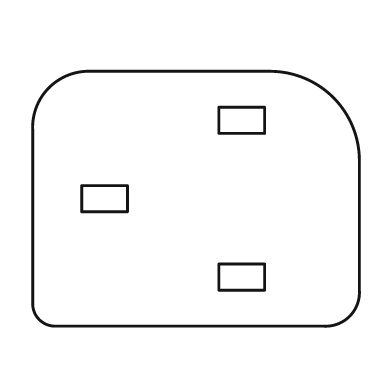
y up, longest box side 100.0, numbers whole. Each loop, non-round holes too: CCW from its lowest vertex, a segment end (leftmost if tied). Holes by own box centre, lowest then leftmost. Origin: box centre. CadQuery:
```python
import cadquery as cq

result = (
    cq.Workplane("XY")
    .moveTo(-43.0, -39.0)
    .lineTo(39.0, -39.0)
    .threePointArc((47.0, -36.0), (50.0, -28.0))
    .lineTo(50.0, 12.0)
    .threePointArc((42.0, 31.0), (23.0, 39.0))
    .lineTo(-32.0, 39.0)
    .threePointArc((-45.0, 34.0), (-50.0, 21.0))
    .lineTo(-50.0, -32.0)
    .threePointArc((-48.0, -37.0), (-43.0, -39.0))
    .close()
    .moveTo(7.0, -28.0)
    .lineTo(21.0, -28.0)
    .lineTo(21.0, -20.0)
    .lineTo(7.0, -20.0)
    .close()
    .moveTo(-35.0, -4.0)
    .lineTo(-21.0, -4.0)
    .lineTo(-21.0, 4.0)
    .lineTo(-35.0, 4.0)
    .close()
    .moveTo(7.0, 20.0)
    .lineTo(21.0, 20.0)
    .lineTo(21.0, 28.0)
    .lineTo(7.0, 28.0)
    .close()
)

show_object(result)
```